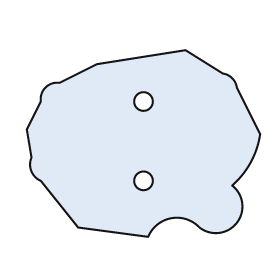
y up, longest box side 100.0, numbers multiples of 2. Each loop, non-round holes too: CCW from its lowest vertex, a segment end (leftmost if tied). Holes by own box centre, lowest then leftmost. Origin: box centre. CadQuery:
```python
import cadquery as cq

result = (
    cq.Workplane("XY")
    .moveTo(2.0, -40.0)
    .threePointArc((12.0, -32.0), (24.0, -36.0))
    .threePointArc((40.0, -34.0), (38.0, -18.0))
    .threePointArc((46.0, -8.0), (50.0, 4.0))
    .lineTo(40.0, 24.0)
    .threePointArc((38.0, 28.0), (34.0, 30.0))
    .lineTo(18.0, 40.0)
    .lineTo(-20.0, 34.0)
    .lineTo(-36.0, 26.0)
    .threePointArc((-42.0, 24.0), (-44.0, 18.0))
    .lineTo(-50.0, 6.0)
    .lineTo(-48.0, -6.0)
    .threePointArc((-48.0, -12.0), (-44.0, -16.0))
    .lineTo(-28.0, -36.0)
    .close()
    .moveTo(0.0, -16.0)
    .circle(4.0)
    .moveTo(0.0, 18.0)
    .circle(4.0)
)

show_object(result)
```